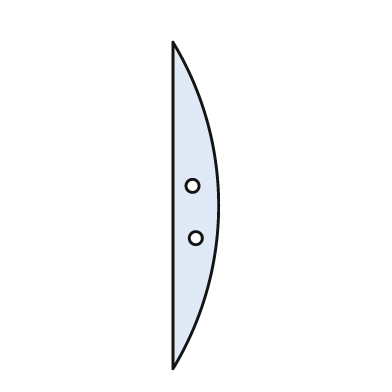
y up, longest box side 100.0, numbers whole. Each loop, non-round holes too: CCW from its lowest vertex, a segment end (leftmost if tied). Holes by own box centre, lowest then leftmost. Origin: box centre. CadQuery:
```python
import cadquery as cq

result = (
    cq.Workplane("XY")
    .moveTo(-7.0, -50.0)
    .threePointArc((7.0, 0.0), (-7.0, 50.0))
    .close()
    .moveTo(0.0, -10.0)
    .circle(2.0)
    .moveTo(-1.0, 6.0)
    .circle(2.0)
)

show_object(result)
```